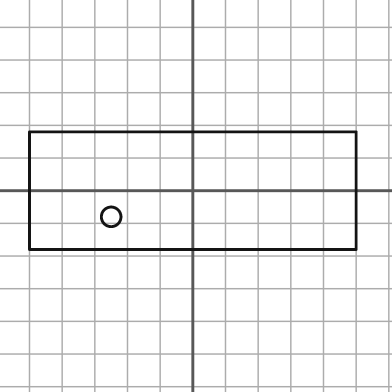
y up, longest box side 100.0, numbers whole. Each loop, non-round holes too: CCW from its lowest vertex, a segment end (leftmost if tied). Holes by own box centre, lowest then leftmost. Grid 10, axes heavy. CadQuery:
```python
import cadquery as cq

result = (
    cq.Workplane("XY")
    .moveTo(-50.0, -18.0)
    .lineTo(50.0, -18.0)
    .lineTo(50.0, 18.0)
    .lineTo(-50.0, 18.0)
    .close()
    .moveTo(-25.0, -8.0)
    .circle(3.0)
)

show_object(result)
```